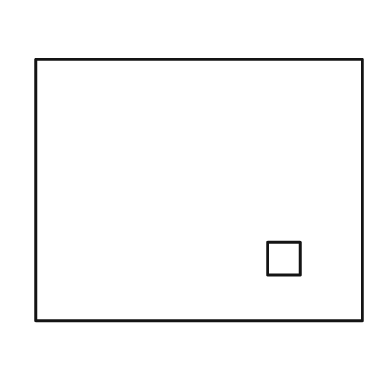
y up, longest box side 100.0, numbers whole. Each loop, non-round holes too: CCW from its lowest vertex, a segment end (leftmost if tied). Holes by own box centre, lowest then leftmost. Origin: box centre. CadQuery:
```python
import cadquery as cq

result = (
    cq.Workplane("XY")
    .moveTo(-50.0, -40.0)
    .lineTo(50.0, -40.0)
    .lineTo(50.0, 40.0)
    .lineTo(-50.0, 40.0)
    .close()
    .moveTo(21.0, -26.0)
    .lineTo(31.0, -26.0)
    .lineTo(31.0, -16.0)
    .lineTo(21.0, -16.0)
    .close()
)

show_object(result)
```